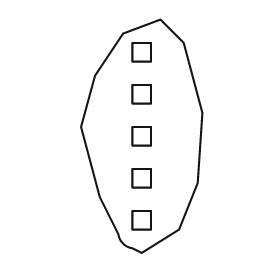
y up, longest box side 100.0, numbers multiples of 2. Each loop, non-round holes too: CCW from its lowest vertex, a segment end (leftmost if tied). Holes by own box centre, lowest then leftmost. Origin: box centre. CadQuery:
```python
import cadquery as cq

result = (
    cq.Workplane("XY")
    .moveTo(0.0, -50.0)
    .lineTo(16.0, -40.0)
    .lineTo(24.0, -20.0)
    .lineTo(26.0, 10.0)
    .lineTo(18.0, 40.0)
    .lineTo(8.0, 50.0)
    .lineTo(-8.0, 44.0)
    .lineTo(-20.0, 26.0)
    .lineTo(-26.0, 4.0)
    .lineTo(-18.0, -26.0)
    .lineTo(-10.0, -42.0)
    .threePointArc((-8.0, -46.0), (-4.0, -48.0))
    .close()
    .moveTo(-4.0, -40.0)
    .lineTo(4.0, -40.0)
    .lineTo(4.0, -32.0)
    .lineTo(-4.0, -32.0)
    .close()
    .moveTo(-4.0, -22.0)
    .lineTo(4.0, -22.0)
    .lineTo(4.0, -14.0)
    .lineTo(-4.0, -14.0)
    .close()
    .moveTo(-4.0, -4.0)
    .lineTo(4.0, -4.0)
    .lineTo(4.0, 4.0)
    .lineTo(-4.0, 4.0)
    .close()
    .moveTo(-4.0, 14.0)
    .lineTo(4.0, 14.0)
    .lineTo(4.0, 22.0)
    .lineTo(-4.0, 22.0)
    .close()
    .moveTo(-4.0, 32.0)
    .lineTo(4.0, 32.0)
    .lineTo(4.0, 40.0)
    .lineTo(-4.0, 40.0)
    .close()
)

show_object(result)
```